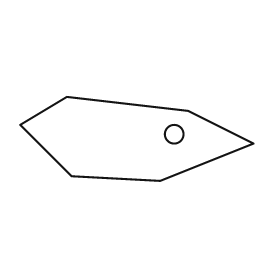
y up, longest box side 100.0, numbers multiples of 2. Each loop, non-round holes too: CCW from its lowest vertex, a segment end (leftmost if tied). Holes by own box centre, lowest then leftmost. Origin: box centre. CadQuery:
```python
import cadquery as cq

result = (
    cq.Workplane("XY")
    .moveTo(10.0, -18.0)
    .lineTo(50.0, -2.0)
    .lineTo(22.0, 12.0)
    .lineTo(-30.0, 18.0)
    .lineTo(-50.0, 6.0)
    .lineTo(-28.0, -16.0)
    .close()
    .moveTo(16.0, 2.0)
    .circle(4.0)
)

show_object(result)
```